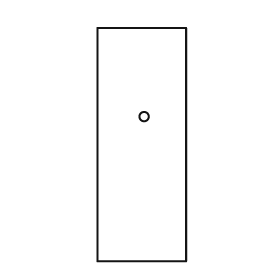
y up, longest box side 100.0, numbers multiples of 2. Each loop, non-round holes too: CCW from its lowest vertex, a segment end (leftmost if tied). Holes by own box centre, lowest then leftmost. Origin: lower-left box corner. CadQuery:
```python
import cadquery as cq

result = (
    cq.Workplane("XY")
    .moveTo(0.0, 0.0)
    .lineTo(38.0, 0.0)
    .lineTo(38.0, 100.0)
    .lineTo(0.0, 100.0)
    .close()
    .moveTo(20.0, 62.0)
    .circle(2.0)
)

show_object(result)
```